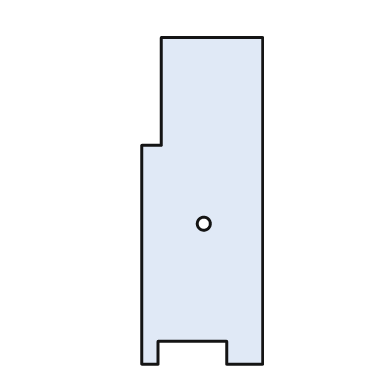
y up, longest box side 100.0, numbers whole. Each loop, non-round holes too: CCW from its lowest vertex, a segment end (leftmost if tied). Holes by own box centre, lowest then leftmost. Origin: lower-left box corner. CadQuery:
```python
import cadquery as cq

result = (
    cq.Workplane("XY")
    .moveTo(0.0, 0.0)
    .lineTo(5.0, 0.0)
    .lineTo(5.0, 7.0)
    .lineTo(26.0, 7.0)
    .lineTo(26.0, 0.0)
    .lineTo(37.0, 0.0)
    .lineTo(37.0, 100.0)
    .lineTo(6.0, 100.0)
    .lineTo(6.0, 67.0)
    .lineTo(0.0, 67.0)
    .close()
    .moveTo(19.0, 43.0)
    .circle(2.0)
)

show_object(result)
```